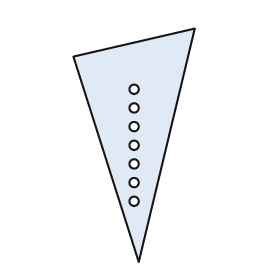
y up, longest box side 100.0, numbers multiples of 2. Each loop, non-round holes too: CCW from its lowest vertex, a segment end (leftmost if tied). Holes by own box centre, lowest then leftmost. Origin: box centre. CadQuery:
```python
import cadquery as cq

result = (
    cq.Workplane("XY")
    .moveTo(2.0, -50.0)
    .lineTo(26.0, 50.0)
    .lineTo(-26.0, 38.0)
    .close()
    .moveTo(0.0, -24.0)
    .circle(2.0)
    .moveTo(0.0, -16.0)
    .circle(2.0)
    .moveTo(0.0, -8.0)
    .circle(2.0)
    .moveTo(0.0, 0.0)
    .circle(2.0)
    .moveTo(0.0, 8.0)
    .circle(2.0)
    .moveTo(0.0, 16.0)
    .circle(2.0)
    .moveTo(0.0, 24.0)
    .circle(2.0)
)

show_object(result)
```